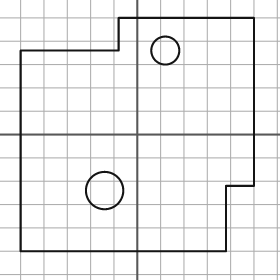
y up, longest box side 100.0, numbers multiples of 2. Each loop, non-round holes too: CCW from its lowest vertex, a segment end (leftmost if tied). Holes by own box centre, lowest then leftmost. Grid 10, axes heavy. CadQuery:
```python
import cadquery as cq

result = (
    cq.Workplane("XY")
    .moveTo(-50.0, -50.0)
    .lineTo(38.0, -50.0)
    .lineTo(38.0, -22.0)
    .lineTo(50.0, -22.0)
    .lineTo(50.0, 50.0)
    .lineTo(-8.0, 50.0)
    .lineTo(-8.0, 36.0)
    .lineTo(-50.0, 36.0)
    .close()
    .moveTo(-14.0, -24.0)
    .circle(8.0)
    .moveTo(12.0, 36.0)
    .circle(6.0)
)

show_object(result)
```